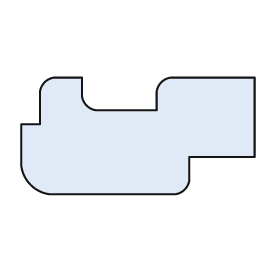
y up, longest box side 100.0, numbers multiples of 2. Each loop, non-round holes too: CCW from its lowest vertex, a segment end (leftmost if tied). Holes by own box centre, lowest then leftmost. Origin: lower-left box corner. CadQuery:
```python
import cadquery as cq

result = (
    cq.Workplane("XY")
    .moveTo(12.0, 0.0)
    .lineTo(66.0, 0.0)
    .threePointArc((70.0, 2.0), (72.0, 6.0))
    .lineTo(72.0, 16.0)
    .lineTo(100.0, 16.0)
    .lineTo(100.0, 50.0)
    .lineTo(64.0, 50.0)
    .threePointArc((60.0, 48.0), (58.0, 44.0))
    .lineTo(58.0, 36.0)
    .lineTo(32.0, 36.0)
    .threePointArc((28.0, 38.0), (26.0, 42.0))
    .lineTo(26.0, 50.0)
    .lineTo(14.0, 50.0)
    .threePointArc((10.0, 48.0), (8.0, 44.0))
    .lineTo(8.0, 30.0)
    .lineTo(0.0, 30.0)
    .lineTo(0.0, 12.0)
    .threePointArc((4.0, 4.0), (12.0, 0.0))
    .close()
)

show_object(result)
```